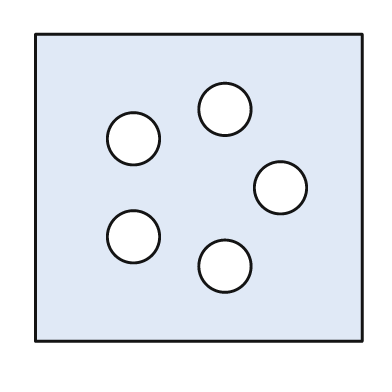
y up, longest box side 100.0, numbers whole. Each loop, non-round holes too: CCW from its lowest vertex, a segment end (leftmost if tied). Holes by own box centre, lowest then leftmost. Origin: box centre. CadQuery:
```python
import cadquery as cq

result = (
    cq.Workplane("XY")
    .moveTo(-50.0, -47.0)
    .lineTo(50.0, -47.0)
    .lineTo(50.0, 47.0)
    .lineTo(-50.0, 47.0)
    .close()
    .moveTo(8.0, -24.0)
    .circle(8.0)
    .moveTo(-20.0, -15.0)
    .circle(8.0)
    .moveTo(25.0, 0.0)
    .circle(8.0)
    .moveTo(-20.0, 15.0)
    .circle(8.0)
    .moveTo(8.0, 24.0)
    .circle(8.0)
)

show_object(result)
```